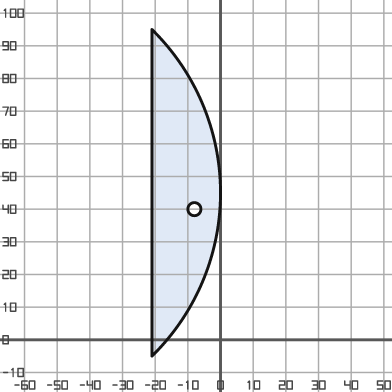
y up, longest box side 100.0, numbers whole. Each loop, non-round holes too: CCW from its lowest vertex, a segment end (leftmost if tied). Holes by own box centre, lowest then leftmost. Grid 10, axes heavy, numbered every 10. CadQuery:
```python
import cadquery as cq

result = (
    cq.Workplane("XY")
    .moveTo(-21.0, -5.0)
    .threePointArc((0.0, 45.0), (-21.0, 95.0))
    .close()
    .moveTo(-8.0, 40.0)
    .circle(2.0)
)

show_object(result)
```